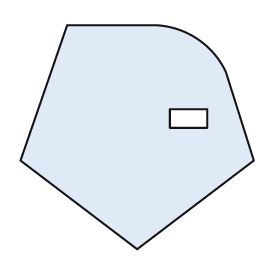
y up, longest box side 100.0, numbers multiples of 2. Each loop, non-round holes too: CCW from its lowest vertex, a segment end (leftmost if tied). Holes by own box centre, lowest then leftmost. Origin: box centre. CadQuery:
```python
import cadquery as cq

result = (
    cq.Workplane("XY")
    .moveTo(0.0, -48.0)
    .lineTo(50.0, -10.0)
    .lineTo(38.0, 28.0)
    .threePointArc((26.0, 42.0), (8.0, 48.0))
    .lineTo(-30.0, 48.0)
    .lineTo(-50.0, -10.0)
    .close()
    .moveTo(14.0, 4.0)
    .lineTo(30.0, 4.0)
    .lineTo(30.0, 12.0)
    .lineTo(14.0, 12.0)
    .close()
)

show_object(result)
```